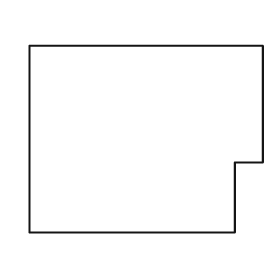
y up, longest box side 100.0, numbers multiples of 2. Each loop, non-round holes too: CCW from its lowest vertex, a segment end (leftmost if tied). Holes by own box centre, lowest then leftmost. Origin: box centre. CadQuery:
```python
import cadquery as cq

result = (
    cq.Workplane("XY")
    .moveTo(-50.0, -40.0)
    .lineTo(38.0, -40.0)
    .lineTo(38.0, -10.0)
    .lineTo(50.0, -10.0)
    .lineTo(50.0, 40.0)
    .lineTo(-50.0, 40.0)
    .close()
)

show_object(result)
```